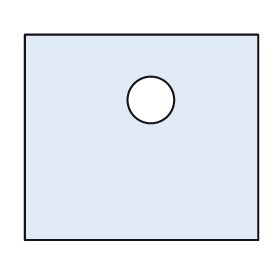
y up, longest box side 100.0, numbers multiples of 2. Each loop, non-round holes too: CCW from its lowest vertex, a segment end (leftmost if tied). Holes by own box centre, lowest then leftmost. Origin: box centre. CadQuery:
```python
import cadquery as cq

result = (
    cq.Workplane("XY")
    .moveTo(-50.0, -44.0)
    .lineTo(50.0, -44.0)
    .lineTo(50.0, 44.0)
    .lineTo(-50.0, 44.0)
    .close()
    .moveTo(4.0, 16.0)
    .circle(10.0)
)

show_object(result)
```